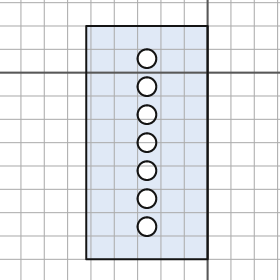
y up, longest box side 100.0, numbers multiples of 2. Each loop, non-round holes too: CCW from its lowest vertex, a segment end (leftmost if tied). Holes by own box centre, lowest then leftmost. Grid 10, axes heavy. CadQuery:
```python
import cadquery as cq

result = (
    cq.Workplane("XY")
    .moveTo(-52.0, -80.0)
    .lineTo(0.0, -80.0)
    .lineTo(0.0, 20.0)
    .lineTo(-52.0, 20.0)
    .close()
    .moveTo(-26.0, -66.0)
    .circle(4.0)
    .moveTo(-26.0, -54.0)
    .circle(4.0)
    .moveTo(-26.0, -42.0)
    .circle(4.0)
    .moveTo(-26.0, -30.0)
    .circle(4.0)
    .moveTo(-26.0, -18.0)
    .circle(4.0)
    .moveTo(-26.0, -6.0)
    .circle(4.0)
    .moveTo(-26.0, 6.0)
    .circle(4.0)
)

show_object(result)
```